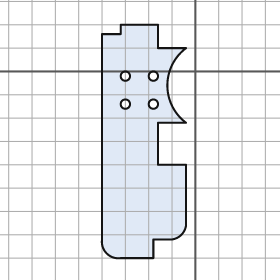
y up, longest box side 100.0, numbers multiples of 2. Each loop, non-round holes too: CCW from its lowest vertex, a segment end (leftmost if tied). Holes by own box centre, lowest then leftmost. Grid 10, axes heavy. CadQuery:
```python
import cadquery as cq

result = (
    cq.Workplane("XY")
    .moveTo(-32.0, -80.0)
    .lineTo(-18.0, -80.0)
    .lineTo(-18.0, -72.0)
    .lineTo(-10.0, -72.0)
    .threePointArc((-6.0, -70.0), (-4.0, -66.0))
    .lineTo(-4.0, -40.0)
    .lineTo(-16.0, -40.0)
    .lineTo(-16.0, -22.0)
    .lineTo(-4.0, -22.0)
    .threePointArc((-12.0, -6.0), (-4.0, 10.0))
    .lineTo(-16.0, 10.0)
    .lineTo(-16.0, 20.0)
    .lineTo(-32.0, 20.0)
    .lineTo(-32.0, 16.0)
    .lineTo(-40.0, 16.0)
    .lineTo(-40.0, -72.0)
    .threePointArc((-38.0, -78.0), (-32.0, -80.0))
    .close()
    .moveTo(-30.0, -14.0)
    .circle(2.0)
    .moveTo(-18.0, -14.0)
    .circle(2.0)
    .moveTo(-30.0, -2.0)
    .circle(2.0)
    .moveTo(-18.0, -2.0)
    .circle(2.0)
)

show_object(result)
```